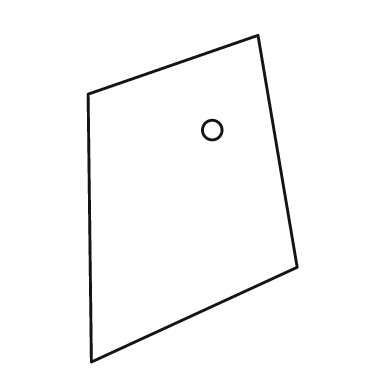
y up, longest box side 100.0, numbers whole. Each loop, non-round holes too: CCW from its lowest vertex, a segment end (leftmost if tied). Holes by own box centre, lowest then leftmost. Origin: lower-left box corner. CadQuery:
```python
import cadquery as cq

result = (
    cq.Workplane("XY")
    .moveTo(1.0, 0.0)
    .lineTo(64.0, 29.0)
    .lineTo(52.0, 100.0)
    .lineTo(0.0, 82.0)
    .close()
    .moveTo(38.0, 71.0)
    .circle(3.0)
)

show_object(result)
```